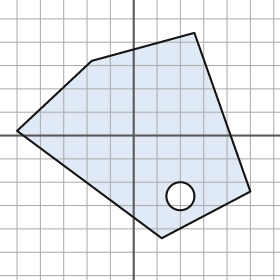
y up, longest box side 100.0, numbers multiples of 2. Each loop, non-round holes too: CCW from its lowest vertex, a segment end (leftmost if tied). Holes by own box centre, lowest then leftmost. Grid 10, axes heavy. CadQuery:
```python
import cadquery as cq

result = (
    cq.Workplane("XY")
    .moveTo(12.0, -44.0)
    .lineTo(50.0, -24.0)
    .lineTo(26.0, 44.0)
    .lineTo(-18.0, 32.0)
    .lineTo(-50.0, 2.0)
    .close()
    .moveTo(20.0, -26.0)
    .circle(6.0)
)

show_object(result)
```